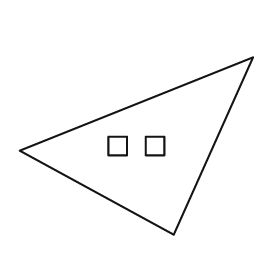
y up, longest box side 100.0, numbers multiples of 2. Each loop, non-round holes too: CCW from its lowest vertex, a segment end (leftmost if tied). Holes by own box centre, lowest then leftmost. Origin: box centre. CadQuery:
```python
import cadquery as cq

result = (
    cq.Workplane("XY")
    .moveTo(16.0, -38.0)
    .lineTo(50.0, 38.0)
    .lineTo(-50.0, -2.0)
    .close()
    .moveTo(-12.0, -4.0)
    .lineTo(-4.0, -4.0)
    .lineTo(-4.0, 4.0)
    .lineTo(-12.0, 4.0)
    .close()
    .moveTo(4.0, -4.0)
    .lineTo(12.0, -4.0)
    .lineTo(12.0, 4.0)
    .lineTo(4.0, 4.0)
    .close()
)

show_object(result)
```